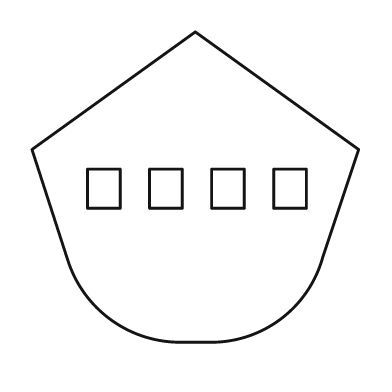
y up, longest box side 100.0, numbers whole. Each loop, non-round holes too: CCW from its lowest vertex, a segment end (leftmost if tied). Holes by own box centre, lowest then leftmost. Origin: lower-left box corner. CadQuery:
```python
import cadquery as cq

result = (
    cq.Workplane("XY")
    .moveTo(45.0, 0.0)
    .lineTo(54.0, 0.0)
    .threePointArc((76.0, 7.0), (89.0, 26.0))
    .lineTo(100.0, 59.0)
    .lineTo(50.0, 95.0)
    .lineTo(0.0, 59.0)
    .lineTo(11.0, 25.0)
    .threePointArc((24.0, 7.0), (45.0, 0.0))
    .close()
    .moveTo(17.0, 41.0)
    .lineTo(27.0, 41.0)
    .lineTo(27.0, 53.0)
    .lineTo(17.0, 53.0)
    .close()
    .moveTo(36.0, 41.0)
    .lineTo(46.0, 41.0)
    .lineTo(46.0, 53.0)
    .lineTo(36.0, 53.0)
    .close()
    .moveTo(55.0, 41.0)
    .lineTo(65.0, 41.0)
    .lineTo(65.0, 53.0)
    .lineTo(55.0, 53.0)
    .close()
    .moveTo(74.0, 41.0)
    .lineTo(84.0, 41.0)
    .lineTo(84.0, 53.0)
    .lineTo(74.0, 53.0)
    .close()
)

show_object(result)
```